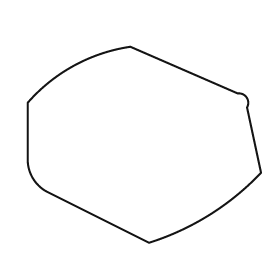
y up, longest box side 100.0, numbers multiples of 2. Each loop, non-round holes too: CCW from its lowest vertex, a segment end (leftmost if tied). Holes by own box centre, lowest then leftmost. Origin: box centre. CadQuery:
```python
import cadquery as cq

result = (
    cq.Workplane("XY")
    .moveTo(2.0, -42.0)
    .threePointArc((28.0, -30.0), (50.0, -12.0))
    .lineTo(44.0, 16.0)
    .threePointArc((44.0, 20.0), (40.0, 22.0))
    .lineTo(-6.0, 42.0)
    .threePointArc((-30.0, 34.0), (-50.0, 18.0))
    .lineTo(-50.0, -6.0)
    .threePointArc((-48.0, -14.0), (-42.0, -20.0))
    .close()
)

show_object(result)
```